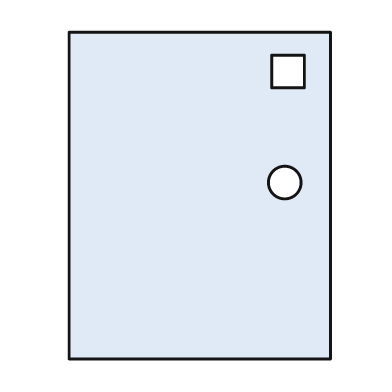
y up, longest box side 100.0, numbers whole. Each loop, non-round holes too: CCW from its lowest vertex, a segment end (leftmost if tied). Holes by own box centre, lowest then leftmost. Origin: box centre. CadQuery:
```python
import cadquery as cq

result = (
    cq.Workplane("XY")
    .moveTo(-40.0, -50.0)
    .lineTo(40.0, -50.0)
    .lineTo(40.0, 50.0)
    .lineTo(-40.0, 50.0)
    .close()
    .moveTo(26.0, 4.0)
    .circle(5.0)
    .moveTo(22.0, 33.0)
    .lineTo(32.0, 33.0)
    .lineTo(32.0, 43.0)
    .lineTo(22.0, 43.0)
    .close()
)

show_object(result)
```